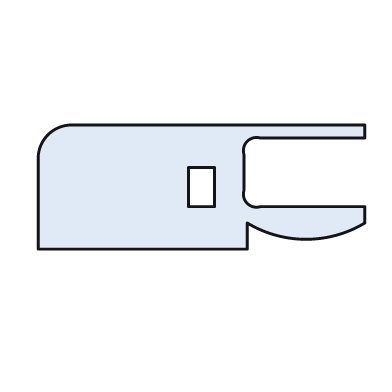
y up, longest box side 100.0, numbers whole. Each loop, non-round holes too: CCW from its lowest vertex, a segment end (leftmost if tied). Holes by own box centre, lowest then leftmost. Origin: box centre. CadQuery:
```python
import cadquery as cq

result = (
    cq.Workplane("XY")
    .moveTo(-50.0, -19.0)
    .lineTo(14.0, -19.0)
    .lineTo(14.0, -11.0)
    .threePointArc((32.0, -16.0), (50.0, -11.0))
    .lineTo(50.0, -6.0)
    .lineTo(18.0, -6.0)
    .threePointArc((14.0, -5.0), (13.0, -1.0))
    .lineTo(13.0, 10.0)
    .threePointArc((14.0, 14.0), (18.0, 15.0))
    .lineTo(50.0, 15.0)
    .lineTo(50.0, 19.0)
    .lineTo(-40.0, 19.0)
    .threePointArc((-47.0, 16.0), (-50.0, 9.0))
    .close()
    .moveTo(-4.0, -6.0)
    .lineTo(4.0, -6.0)
    .lineTo(4.0, 6.0)
    .lineTo(-4.0, 6.0)
    .close()
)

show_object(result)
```